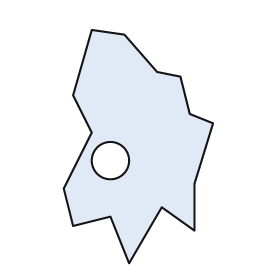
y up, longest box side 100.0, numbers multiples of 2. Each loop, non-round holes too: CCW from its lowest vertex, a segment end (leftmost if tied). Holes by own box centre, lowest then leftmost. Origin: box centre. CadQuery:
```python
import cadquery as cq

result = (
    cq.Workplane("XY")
    .moveTo(-4.0, -50.0)
    .lineTo(10.0, -26.0)
    .lineTo(24.0, -36.0)
    .lineTo(24.0, -16.0)
    .lineTo(32.0, 10.0)
    .lineTo(22.0, 14.0)
    .lineTo(18.0, 30.0)
    .lineTo(8.0, 32.0)
    .lineTo(-6.0, 48.0)
    .lineTo(-20.0, 50.0)
    .lineTo(-28.0, 22.0)
    .lineTo(-20.0, 6.0)
    .lineTo(-32.0, -18.0)
    .lineTo(-28.0, -34.0)
    .lineTo(-12.0, -30.0)
    .close()
    .moveTo(-12.0, -6.0)
    .circle(8.0)
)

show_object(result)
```